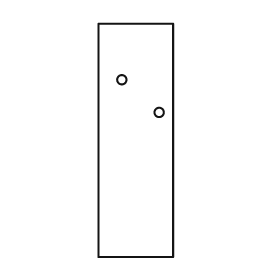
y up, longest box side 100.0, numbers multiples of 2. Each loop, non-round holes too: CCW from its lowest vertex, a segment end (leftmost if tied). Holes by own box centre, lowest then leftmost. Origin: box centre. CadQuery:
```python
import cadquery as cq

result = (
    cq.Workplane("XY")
    .moveTo(-16.0, -50.0)
    .lineTo(16.0, -50.0)
    .lineTo(16.0, 50.0)
    .lineTo(-16.0, 50.0)
    .close()
    .moveTo(10.0, 12.0)
    .circle(2.0)
    .moveTo(-6.0, 26.0)
    .circle(2.0)
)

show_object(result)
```